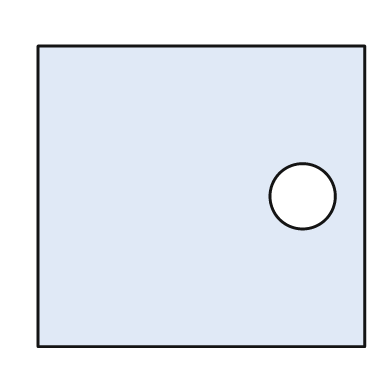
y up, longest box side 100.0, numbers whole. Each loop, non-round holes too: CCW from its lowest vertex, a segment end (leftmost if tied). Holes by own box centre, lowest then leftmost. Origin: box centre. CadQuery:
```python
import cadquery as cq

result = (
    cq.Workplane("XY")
    .moveTo(-50.0, -46.0)
    .lineTo(50.0, -46.0)
    .lineTo(50.0, 46.0)
    .lineTo(-50.0, 46.0)
    .close()
    .moveTo(31.0, 0.0)
    .circle(10.0)
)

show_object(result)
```